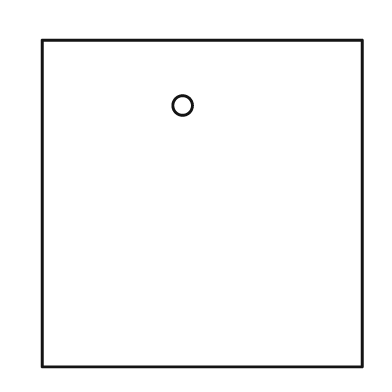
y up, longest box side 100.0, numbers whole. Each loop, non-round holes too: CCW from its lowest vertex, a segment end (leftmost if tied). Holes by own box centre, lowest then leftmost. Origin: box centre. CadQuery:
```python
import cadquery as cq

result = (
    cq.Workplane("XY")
    .moveTo(-49.0, -50.0)
    .lineTo(49.0, -50.0)
    .lineTo(49.0, 50.0)
    .lineTo(-49.0, 50.0)
    .close()
    .moveTo(-6.0, 30.0)
    .circle(3.0)
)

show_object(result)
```